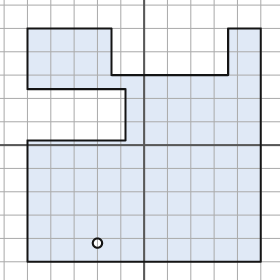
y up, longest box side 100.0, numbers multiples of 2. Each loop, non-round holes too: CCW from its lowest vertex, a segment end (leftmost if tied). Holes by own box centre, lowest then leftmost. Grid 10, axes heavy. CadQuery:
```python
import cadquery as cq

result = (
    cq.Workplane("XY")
    .moveTo(-50.0, -50.0)
    .lineTo(50.0, -50.0)
    .lineTo(50.0, 50.0)
    .lineTo(36.0, 50.0)
    .lineTo(36.0, 30.0)
    .lineTo(-14.0, 30.0)
    .lineTo(-14.0, 50.0)
    .lineTo(-50.0, 50.0)
    .lineTo(-50.0, 24.0)
    .lineTo(-8.0, 24.0)
    .lineTo(-8.0, 2.0)
    .lineTo(-50.0, 2.0)
    .close()
    .moveTo(-20.0, -42.0)
    .circle(2.0)
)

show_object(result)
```